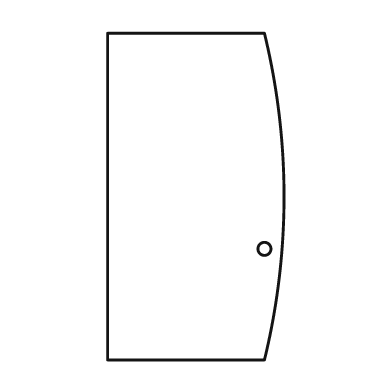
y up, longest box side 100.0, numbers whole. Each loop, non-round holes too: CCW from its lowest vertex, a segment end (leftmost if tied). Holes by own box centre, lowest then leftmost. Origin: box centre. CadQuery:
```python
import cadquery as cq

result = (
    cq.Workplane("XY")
    .moveTo(-27.0, -50.0)
    .lineTo(21.0, -50.0)
    .threePointArc((27.0, 0.0), (21.0, 50.0))
    .lineTo(-27.0, 50.0)
    .close()
    .moveTo(21.0, -16.0)
    .circle(2.0)
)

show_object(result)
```